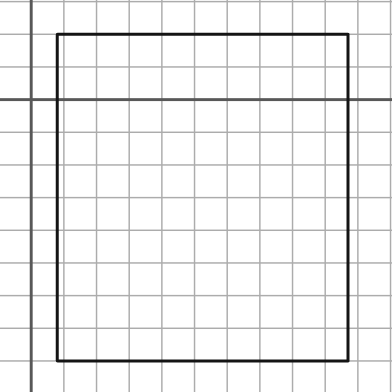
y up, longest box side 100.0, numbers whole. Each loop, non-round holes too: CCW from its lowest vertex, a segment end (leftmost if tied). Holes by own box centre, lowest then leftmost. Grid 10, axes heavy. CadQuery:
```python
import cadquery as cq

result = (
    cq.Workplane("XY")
    .moveTo(8.0, -80.0)
    .lineTo(97.0, -80.0)
    .lineTo(97.0, 20.0)
    .lineTo(8.0, 20.0)
    .close()
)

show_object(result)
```